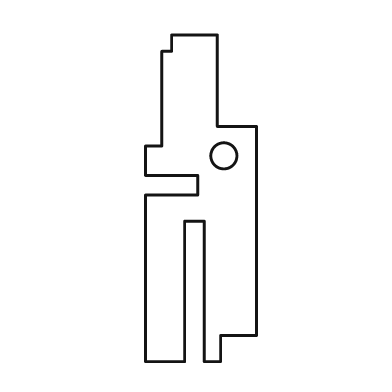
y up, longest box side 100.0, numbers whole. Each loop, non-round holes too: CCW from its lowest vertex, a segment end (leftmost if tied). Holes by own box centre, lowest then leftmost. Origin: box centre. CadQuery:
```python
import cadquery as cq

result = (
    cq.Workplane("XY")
    .moveTo(-17.0, -50.0)
    .lineTo(-5.0, -50.0)
    .lineTo(-5.0, -7.0)
    .lineTo(1.0, -7.0)
    .lineTo(1.0, -50.0)
    .lineTo(6.0, -50.0)
    .lineTo(6.0, -42.0)
    .lineTo(17.0, -42.0)
    .lineTo(17.0, 22.0)
    .lineTo(5.0, 22.0)
    .lineTo(5.0, 50.0)
    .lineTo(-9.0, 50.0)
    .lineTo(-9.0, 45.0)
    .lineTo(-12.0, 45.0)
    .lineTo(-12.0, 16.0)
    .lineTo(-17.0, 16.0)
    .lineTo(-17.0, 7.0)
    .lineTo(-1.0, 7.0)
    .lineTo(-1.0, 1.0)
    .lineTo(-17.0, 1.0)
    .close()
    .moveTo(7.0, 13.0)
    .circle(4.0)
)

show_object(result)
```